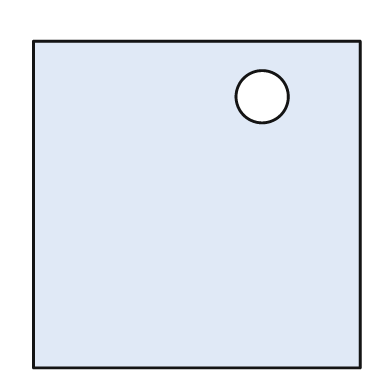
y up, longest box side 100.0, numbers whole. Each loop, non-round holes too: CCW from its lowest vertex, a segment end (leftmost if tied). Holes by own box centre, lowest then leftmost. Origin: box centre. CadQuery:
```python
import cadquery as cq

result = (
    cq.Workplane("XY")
    .moveTo(-50.0, -50.0)
    .lineTo(50.0, -50.0)
    .lineTo(50.0, 50.0)
    .lineTo(-50.0, 50.0)
    .close()
    .moveTo(20.0, 33.0)
    .circle(8.0)
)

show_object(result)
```